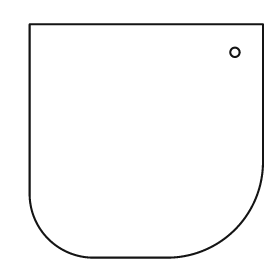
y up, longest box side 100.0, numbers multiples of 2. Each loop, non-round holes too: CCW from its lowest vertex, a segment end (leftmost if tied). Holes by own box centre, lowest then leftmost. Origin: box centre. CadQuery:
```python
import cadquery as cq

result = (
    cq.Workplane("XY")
    .moveTo(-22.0, -50.0)
    .lineTo(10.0, -50.0)
    .threePointArc((38.0, -38.0), (50.0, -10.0))
    .lineTo(50.0, 50.0)
    .lineTo(-50.0, 50.0)
    .lineTo(-50.0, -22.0)
    .threePointArc((-42.0, -42.0), (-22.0, -50.0))
    .close()
    .moveTo(38.0, 38.0)
    .circle(2.0)
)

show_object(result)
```